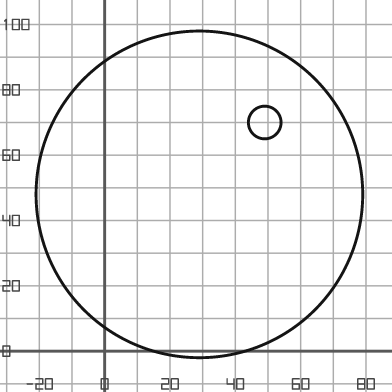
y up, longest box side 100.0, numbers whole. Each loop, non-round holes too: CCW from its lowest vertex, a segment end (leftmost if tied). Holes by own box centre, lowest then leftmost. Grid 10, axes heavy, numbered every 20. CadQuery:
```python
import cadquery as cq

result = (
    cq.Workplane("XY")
    .moveTo(29.0, 48.0)
    .circle(50.0)
    .moveTo(49.0, 70.0)
    .circle(5.0)
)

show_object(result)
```